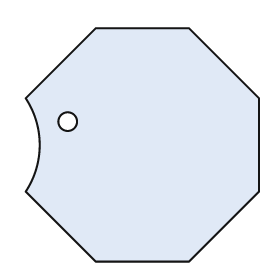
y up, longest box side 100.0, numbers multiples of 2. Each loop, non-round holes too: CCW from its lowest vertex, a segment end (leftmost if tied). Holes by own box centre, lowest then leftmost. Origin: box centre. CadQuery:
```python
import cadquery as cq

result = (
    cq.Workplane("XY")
    .moveTo(-20.0, -50.0)
    .lineTo(20.0, -50.0)
    .lineTo(50.0, -20.0)
    .lineTo(50.0, 20.0)
    .lineTo(20.0, 50.0)
    .lineTo(-20.0, 50.0)
    .lineTo(-50.0, 20.0)
    .threePointArc((-44.0, 0.0), (-50.0, -20.0))
    .close()
    .moveTo(-32.0, 10.0)
    .circle(4.0)
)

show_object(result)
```